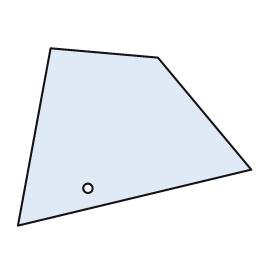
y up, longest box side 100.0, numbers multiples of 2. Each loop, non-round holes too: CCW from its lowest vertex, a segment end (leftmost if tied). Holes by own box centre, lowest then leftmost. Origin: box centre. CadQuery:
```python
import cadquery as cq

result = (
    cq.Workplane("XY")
    .moveTo(-50.0, -38.0)
    .lineTo(50.0, -14.0)
    .lineTo(10.0, 34.0)
    .lineTo(-36.0, 38.0)
    .close()
    .moveTo(-20.0, -22.0)
    .circle(2.0)
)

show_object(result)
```